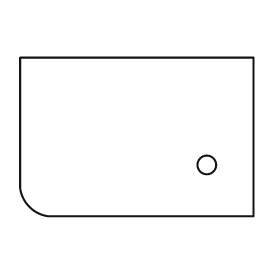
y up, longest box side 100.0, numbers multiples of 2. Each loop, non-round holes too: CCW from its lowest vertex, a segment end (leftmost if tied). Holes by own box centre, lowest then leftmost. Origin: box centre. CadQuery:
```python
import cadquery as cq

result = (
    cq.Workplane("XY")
    .moveTo(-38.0, -34.0)
    .lineTo(50.0, -34.0)
    .lineTo(50.0, 34.0)
    .lineTo(-50.0, 34.0)
    .lineTo(-50.0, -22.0)
    .threePointArc((-46.0, -30.0), (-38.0, -34.0))
    .close()
    .moveTo(30.0, -12.0)
    .circle(4.0)
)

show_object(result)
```